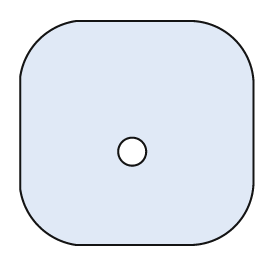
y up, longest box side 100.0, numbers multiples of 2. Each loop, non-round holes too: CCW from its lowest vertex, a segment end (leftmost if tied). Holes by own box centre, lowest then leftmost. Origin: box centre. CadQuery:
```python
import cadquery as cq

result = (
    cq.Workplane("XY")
    .moveTo(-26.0, -48.0)
    .lineTo(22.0, -48.0)
    .threePointArc((42.0, -40.0), (50.0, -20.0))
    .lineTo(50.0, 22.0)
    .threePointArc((42.0, 40.0), (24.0, 48.0))
    .lineTo(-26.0, 48.0)
    .threePointArc((-42.0, 40.0), (-50.0, 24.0))
    .lineTo(-50.0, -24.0)
    .threePointArc((-42.0, -40.0), (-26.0, -48.0))
    .close()
    .moveTo(-2.0, -8.0)
    .circle(6.0)
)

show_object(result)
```